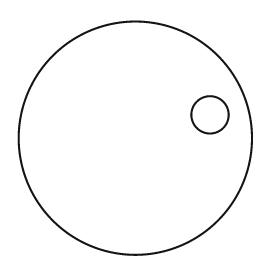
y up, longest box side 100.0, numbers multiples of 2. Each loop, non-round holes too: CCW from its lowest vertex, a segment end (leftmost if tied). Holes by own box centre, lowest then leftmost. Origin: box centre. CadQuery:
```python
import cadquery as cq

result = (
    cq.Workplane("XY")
    .moveTo(0.0, 0.0)
    .circle(50.0)
    .moveTo(32.0, 10.0)
    .circle(8.0)
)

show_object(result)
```